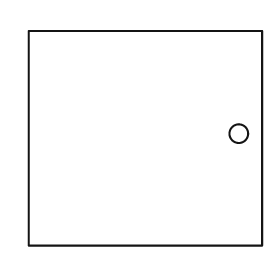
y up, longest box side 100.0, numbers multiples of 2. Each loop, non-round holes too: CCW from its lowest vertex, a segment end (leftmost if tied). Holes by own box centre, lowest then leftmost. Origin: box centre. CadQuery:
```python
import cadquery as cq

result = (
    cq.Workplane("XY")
    .moveTo(-50.0, -46.0)
    .lineTo(50.0, -46.0)
    .lineTo(50.0, 46.0)
    .lineTo(-50.0, 46.0)
    .close()
    .moveTo(40.0, 2.0)
    .circle(4.0)
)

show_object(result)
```